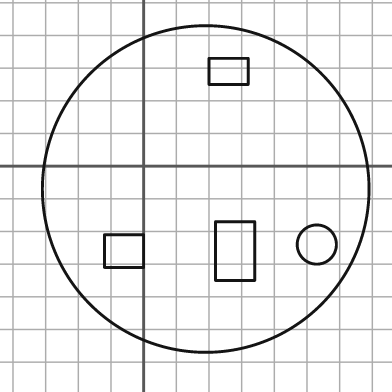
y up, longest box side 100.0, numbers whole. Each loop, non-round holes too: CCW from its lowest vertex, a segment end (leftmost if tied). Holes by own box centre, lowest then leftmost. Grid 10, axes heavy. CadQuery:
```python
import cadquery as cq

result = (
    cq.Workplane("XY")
    .moveTo(19.0, -7.0)
    .circle(50.0)
    .moveTo(-12.0, -31.0)
    .lineTo(0.0, -31.0)
    .lineTo(0.0, -21.0)
    .lineTo(-12.0, -21.0)
    .close()
    .moveTo(22.0, -35.0)
    .lineTo(34.0, -35.0)
    .lineTo(34.0, -17.0)
    .lineTo(22.0, -17.0)
    .close()
    .moveTo(53.0, -24.0)
    .circle(6.0)
    .moveTo(20.0, 25.0)
    .lineTo(32.0, 25.0)
    .lineTo(32.0, 33.0)
    .lineTo(20.0, 33.0)
    .close()
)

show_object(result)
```